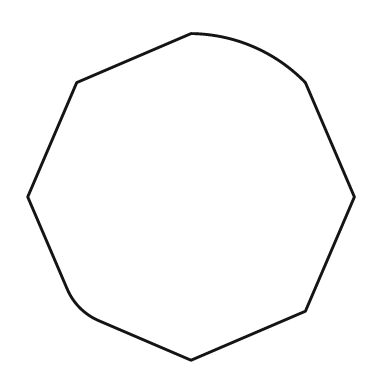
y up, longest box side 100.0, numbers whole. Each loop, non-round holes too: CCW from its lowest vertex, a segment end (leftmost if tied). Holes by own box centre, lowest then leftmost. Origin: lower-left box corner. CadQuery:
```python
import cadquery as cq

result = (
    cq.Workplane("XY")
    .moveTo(50.0, 0.0)
    .lineTo(85.0, 15.0)
    .lineTo(100.0, 50.0)
    .lineTo(85.0, 85.0)
    .threePointArc((69.0, 96.0), (50.0, 100.0))
    .lineTo(15.0, 85.0)
    .lineTo(0.0, 50.0)
    .lineTo(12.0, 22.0)
    .threePointArc((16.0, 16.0), (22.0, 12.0))
    .close()
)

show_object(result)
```